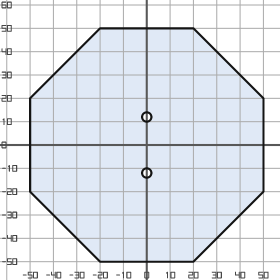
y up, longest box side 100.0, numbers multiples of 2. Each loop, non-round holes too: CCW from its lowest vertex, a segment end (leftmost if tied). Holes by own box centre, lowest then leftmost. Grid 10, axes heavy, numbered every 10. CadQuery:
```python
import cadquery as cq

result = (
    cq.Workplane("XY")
    .moveTo(-20.0, -50.0)
    .lineTo(20.0, -50.0)
    .lineTo(50.0, -20.0)
    .lineTo(50.0, 20.0)
    .lineTo(20.0, 50.0)
    .lineTo(-20.0, 50.0)
    .lineTo(-50.0, 20.0)
    .lineTo(-50.0, -20.0)
    .close()
    .moveTo(0.0, -12.0)
    .circle(2.0)
    .moveTo(0.0, 12.0)
    .circle(2.0)
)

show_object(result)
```